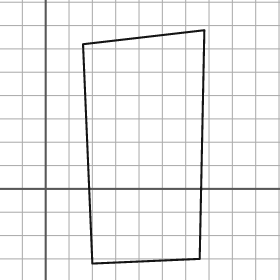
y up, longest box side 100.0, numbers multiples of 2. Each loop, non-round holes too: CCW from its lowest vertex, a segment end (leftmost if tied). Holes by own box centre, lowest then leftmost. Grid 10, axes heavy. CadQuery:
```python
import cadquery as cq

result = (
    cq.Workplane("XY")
    .moveTo(20.0, -32.0)
    .lineTo(66.0, -30.0)
    .lineTo(68.0, 68.0)
    .lineTo(16.0, 62.0)
    .close()
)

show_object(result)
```